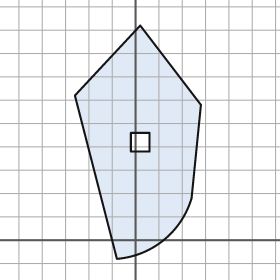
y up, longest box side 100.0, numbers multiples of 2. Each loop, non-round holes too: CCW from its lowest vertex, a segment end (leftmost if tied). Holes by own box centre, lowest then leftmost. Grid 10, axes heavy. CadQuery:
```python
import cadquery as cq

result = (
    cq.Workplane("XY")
    .moveTo(-8.0, -8.0)
    .threePointArc((12.0, 0.0), (24.0, 18.0))
    .lineTo(28.0, 58.0)
    .lineTo(2.0, 92.0)
    .lineTo(-26.0, 62.0)
    .close()
    .moveTo(-2.0, 38.0)
    .lineTo(6.0, 38.0)
    .lineTo(6.0, 46.0)
    .lineTo(-2.0, 46.0)
    .close()
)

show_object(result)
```